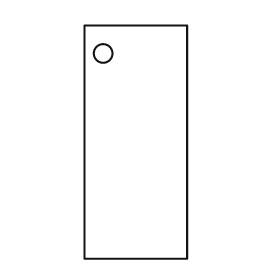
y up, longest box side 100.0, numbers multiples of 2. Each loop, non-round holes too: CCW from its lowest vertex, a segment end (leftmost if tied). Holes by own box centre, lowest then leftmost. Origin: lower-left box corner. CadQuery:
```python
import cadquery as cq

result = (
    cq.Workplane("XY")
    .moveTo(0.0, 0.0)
    .lineTo(44.0, 0.0)
    .lineTo(44.0, 100.0)
    .lineTo(0.0, 100.0)
    .close()
    .moveTo(8.0, 88.0)
    .circle(4.0)
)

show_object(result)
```